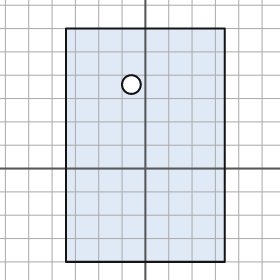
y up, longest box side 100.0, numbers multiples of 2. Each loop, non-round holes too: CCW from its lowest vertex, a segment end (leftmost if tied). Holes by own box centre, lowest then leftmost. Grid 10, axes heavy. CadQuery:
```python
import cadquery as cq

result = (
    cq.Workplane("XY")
    .moveTo(-34.0, -40.0)
    .lineTo(34.0, -40.0)
    .lineTo(34.0, 60.0)
    .lineTo(-34.0, 60.0)
    .close()
    .moveTo(-6.0, 36.0)
    .circle(4.0)
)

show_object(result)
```